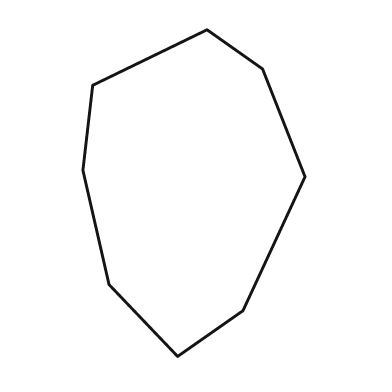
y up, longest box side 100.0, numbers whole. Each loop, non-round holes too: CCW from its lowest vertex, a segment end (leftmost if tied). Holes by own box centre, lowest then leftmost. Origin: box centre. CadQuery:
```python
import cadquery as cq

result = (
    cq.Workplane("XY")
    .moveTo(-5.0, -50.0)
    .lineTo(15.0, -36.0)
    .lineTo(34.0, 5.0)
    .lineTo(21.0, 38.0)
    .lineTo(4.0, 50.0)
    .lineTo(-31.0, 33.0)
    .lineTo(-34.0, 7.0)
    .lineTo(-26.0, -28.0)
    .close()
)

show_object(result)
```